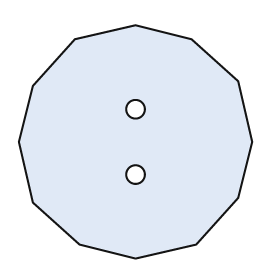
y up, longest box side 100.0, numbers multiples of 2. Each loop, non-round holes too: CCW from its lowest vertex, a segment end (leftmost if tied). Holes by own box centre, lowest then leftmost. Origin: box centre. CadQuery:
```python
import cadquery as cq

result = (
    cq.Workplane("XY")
    .moveTo(0.0, -50.0)
    .lineTo(26.0, -44.0)
    .lineTo(44.0, -24.0)
    .lineTo(50.0, 0.0)
    .lineTo(44.0, 26.0)
    .lineTo(24.0, 44.0)
    .lineTo(0.0, 50.0)
    .lineTo(-26.0, 44.0)
    .lineTo(-44.0, 24.0)
    .lineTo(-50.0, 0.0)
    .lineTo(-44.0, -26.0)
    .lineTo(-24.0, -44.0)
    .close()
    .moveTo(0.0, -14.0)
    .circle(4.0)
    .moveTo(0.0, 14.0)
    .circle(4.0)
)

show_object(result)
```